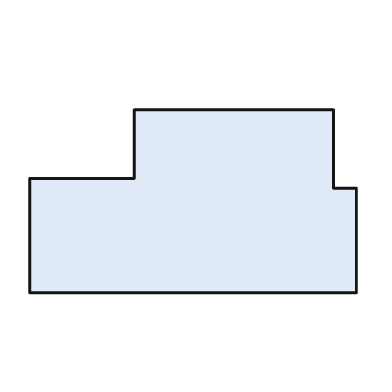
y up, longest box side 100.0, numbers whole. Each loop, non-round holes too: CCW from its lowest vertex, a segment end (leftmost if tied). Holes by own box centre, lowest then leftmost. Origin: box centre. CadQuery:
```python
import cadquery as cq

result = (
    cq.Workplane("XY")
    .moveTo(-50.0, -28.0)
    .lineTo(50.0, -28.0)
    .lineTo(50.0, 4.0)
    .lineTo(43.0, 4.0)
    .lineTo(43.0, 28.0)
    .lineTo(-18.0, 28.0)
    .lineTo(-18.0, 7.0)
    .lineTo(-50.0, 7.0)
    .close()
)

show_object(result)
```